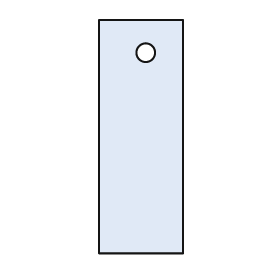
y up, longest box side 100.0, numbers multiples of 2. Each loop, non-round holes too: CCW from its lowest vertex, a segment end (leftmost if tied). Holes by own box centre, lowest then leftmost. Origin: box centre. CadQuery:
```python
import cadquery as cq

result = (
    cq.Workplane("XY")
    .moveTo(-18.0, -50.0)
    .lineTo(18.0, -50.0)
    .lineTo(18.0, 50.0)
    .lineTo(-18.0, 50.0)
    .close()
    .moveTo(2.0, 36.0)
    .circle(4.0)
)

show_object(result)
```